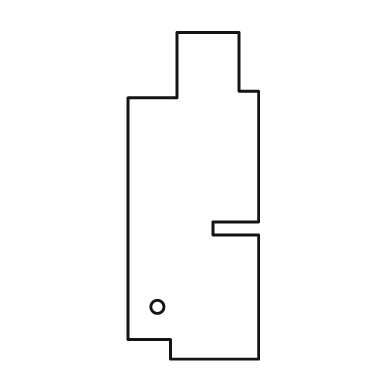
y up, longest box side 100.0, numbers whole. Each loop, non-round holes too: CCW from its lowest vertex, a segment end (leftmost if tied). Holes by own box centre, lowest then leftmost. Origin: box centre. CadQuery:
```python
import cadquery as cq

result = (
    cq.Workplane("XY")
    .moveTo(-7.0, -50.0)
    .lineTo(20.0, -50.0)
    .lineTo(20.0, -12.0)
    .lineTo(6.0, -12.0)
    .lineTo(6.0, -8.0)
    .lineTo(20.0, -8.0)
    .lineTo(20.0, 32.0)
    .lineTo(14.0, 32.0)
    .lineTo(14.0, 50.0)
    .lineTo(-5.0, 50.0)
    .lineTo(-5.0, 30.0)
    .lineTo(-20.0, 30.0)
    .lineTo(-20.0, -44.0)
    .lineTo(-7.0, -44.0)
    .close()
    .moveTo(-11.0, -34.0)
    .circle(2.0)
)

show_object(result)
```